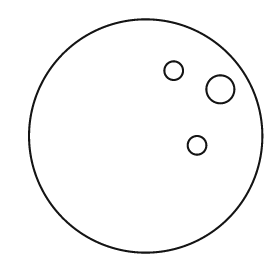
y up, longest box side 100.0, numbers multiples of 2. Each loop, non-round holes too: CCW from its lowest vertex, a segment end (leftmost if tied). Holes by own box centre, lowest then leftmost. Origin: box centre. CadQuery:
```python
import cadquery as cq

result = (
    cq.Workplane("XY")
    .moveTo(0.0, 0.0)
    .circle(50.0)
    .moveTo(22.0, -4.0)
    .circle(4.0)
    .moveTo(32.0, 20.0)
    .circle(6.0)
    .moveTo(12.0, 28.0)
    .circle(4.0)
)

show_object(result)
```